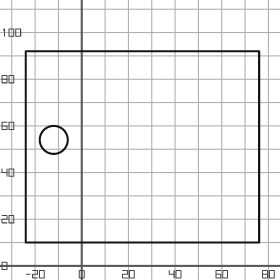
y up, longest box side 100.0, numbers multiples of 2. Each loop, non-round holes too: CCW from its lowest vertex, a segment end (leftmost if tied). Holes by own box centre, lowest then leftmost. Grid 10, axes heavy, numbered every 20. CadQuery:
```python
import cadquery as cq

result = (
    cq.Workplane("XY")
    .moveTo(-24.0, 10.0)
    .lineTo(76.0, 10.0)
    .lineTo(76.0, 92.0)
    .lineTo(-24.0, 92.0)
    .close()
    .moveTo(-12.0, 54.0)
    .circle(6.0)
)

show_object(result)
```